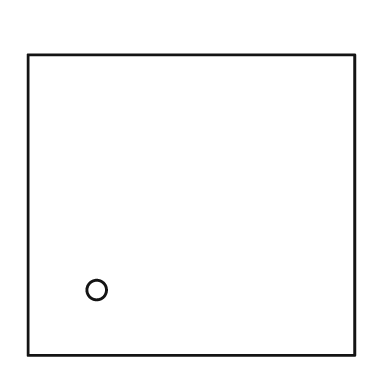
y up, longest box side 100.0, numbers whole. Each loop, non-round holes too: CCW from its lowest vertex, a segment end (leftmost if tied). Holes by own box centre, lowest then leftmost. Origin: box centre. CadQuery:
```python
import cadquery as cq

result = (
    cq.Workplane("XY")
    .moveTo(-50.0, -46.0)
    .lineTo(50.0, -46.0)
    .lineTo(50.0, 46.0)
    .lineTo(-50.0, 46.0)
    .close()
    .moveTo(-29.0, -26.0)
    .circle(3.0)
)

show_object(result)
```